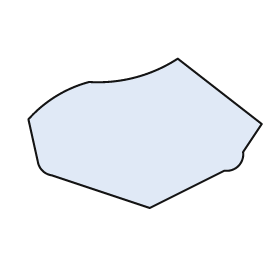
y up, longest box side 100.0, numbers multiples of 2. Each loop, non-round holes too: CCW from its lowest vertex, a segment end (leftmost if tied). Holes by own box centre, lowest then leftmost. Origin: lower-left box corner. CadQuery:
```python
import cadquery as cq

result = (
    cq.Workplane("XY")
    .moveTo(52.0, 0.0)
    .lineTo(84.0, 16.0)
    .threePointArc((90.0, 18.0), (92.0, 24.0))
    .lineTo(100.0, 36.0)
    .lineTo(64.0, 64.0)
    .threePointArc((46.0, 56.0), (26.0, 54.0))
    .threePointArc((12.0, 48.0), (0.0, 38.0))
    .lineTo(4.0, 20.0)
    .threePointArc((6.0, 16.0), (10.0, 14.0))
    .close()
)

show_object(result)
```